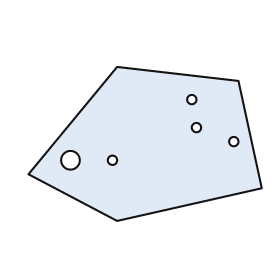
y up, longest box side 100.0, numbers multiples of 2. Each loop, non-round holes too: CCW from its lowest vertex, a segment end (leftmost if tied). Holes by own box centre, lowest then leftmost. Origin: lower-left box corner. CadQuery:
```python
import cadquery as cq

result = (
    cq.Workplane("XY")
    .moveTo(38.0, 0.0)
    .lineTo(100.0, 14.0)
    .lineTo(90.0, 60.0)
    .lineTo(38.0, 66.0)
    .lineTo(0.0, 20.0)
    .close()
    .moveTo(18.0, 26.0)
    .circle(4.0)
    .moveTo(36.0, 26.0)
    .circle(2.0)
    .moveTo(88.0, 34.0)
    .circle(2.0)
    .moveTo(72.0, 40.0)
    .circle(2.0)
    .moveTo(70.0, 52.0)
    .circle(2.0)
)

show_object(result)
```